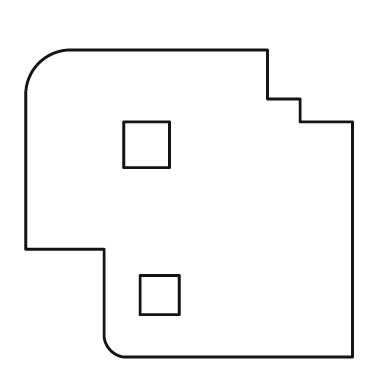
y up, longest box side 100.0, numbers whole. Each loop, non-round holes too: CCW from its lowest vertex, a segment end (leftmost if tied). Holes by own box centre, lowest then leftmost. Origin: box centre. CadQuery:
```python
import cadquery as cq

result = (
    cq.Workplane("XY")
    .moveTo(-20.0, -47.0)
    .lineTo(50.0, -47.0)
    .lineTo(50.0, 25.0)
    .lineTo(34.0, 25.0)
    .lineTo(34.0, 32.0)
    .lineTo(24.0, 32.0)
    .lineTo(24.0, 47.0)
    .lineTo(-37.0, 47.0)
    .threePointArc((-46.0, 43.0), (-50.0, 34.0))
    .lineTo(-50.0, -14.0)
    .lineTo(-26.0, -14.0)
    .lineTo(-26.0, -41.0)
    .threePointArc((-24.0, -45.0), (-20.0, -47.0))
    .close()
    .moveTo(-15.0, -34.0)
    .lineTo(-3.0, -34.0)
    .lineTo(-3.0, -22.0)
    .lineTo(-15.0, -22.0)
    .close()
    .moveTo(-20.0, 11.0)
    .lineTo(-6.0, 11.0)
    .lineTo(-6.0, 25.0)
    .lineTo(-20.0, 25.0)
    .close()
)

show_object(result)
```